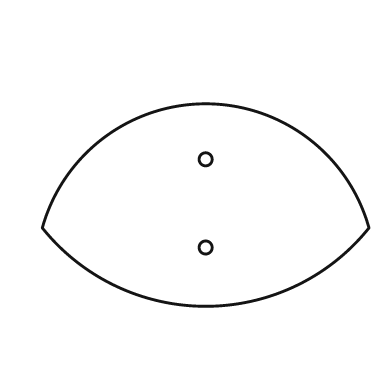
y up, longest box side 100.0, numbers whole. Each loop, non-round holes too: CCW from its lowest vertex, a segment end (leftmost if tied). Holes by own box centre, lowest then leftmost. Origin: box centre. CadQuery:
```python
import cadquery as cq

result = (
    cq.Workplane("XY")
    .moveTo(-50.0, -7.0)
    .threePointArc((0.0, -31.0), (50.0, -7.0))
    .threePointArc((0.0, 31.0), (-50.0, -7.0))
    .close()
    .moveTo(0.0, -13.0)
    .circle(2.0)
    .moveTo(0.0, 14.0)
    .circle(2.0)
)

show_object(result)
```